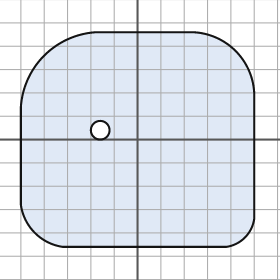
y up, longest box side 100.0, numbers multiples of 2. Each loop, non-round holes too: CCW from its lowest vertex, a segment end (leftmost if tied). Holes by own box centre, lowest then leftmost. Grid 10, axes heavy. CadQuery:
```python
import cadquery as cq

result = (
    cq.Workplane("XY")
    .moveTo(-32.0, -46.0)
    .lineTo(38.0, -46.0)
    .threePointArc((46.0, -42.0), (50.0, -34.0))
    .lineTo(50.0, 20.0)
    .threePointArc((42.0, 38.0), (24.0, 46.0))
    .lineTo(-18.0, 46.0)
    .threePointArc((-40.0, 36.0), (-50.0, 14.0))
    .lineTo(-50.0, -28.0)
    .threePointArc((-44.0, -40.0), (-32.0, -46.0))
    .close()
    .moveTo(-16.0, 4.0)
    .circle(4.0)
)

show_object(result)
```